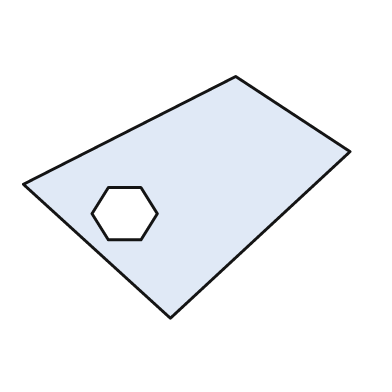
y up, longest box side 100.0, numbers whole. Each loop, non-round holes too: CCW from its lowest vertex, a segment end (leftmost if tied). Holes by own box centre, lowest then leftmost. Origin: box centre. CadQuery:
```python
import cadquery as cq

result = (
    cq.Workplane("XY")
    .moveTo(-5.0, -37.0)
    .lineTo(50.0, 14.0)
    .lineTo(15.0, 37.0)
    .lineTo(-50.0, 4.0)
    .close()
    .moveTo(-24.0, -13.0)
    .lineTo(-14.0, -13.0)
    .lineTo(-9.0, -5.0)
    .lineTo(-14.0, 3.0)
    .lineTo(-24.0, 3.0)
    .lineTo(-29.0, -5.0)
    .close()
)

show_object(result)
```